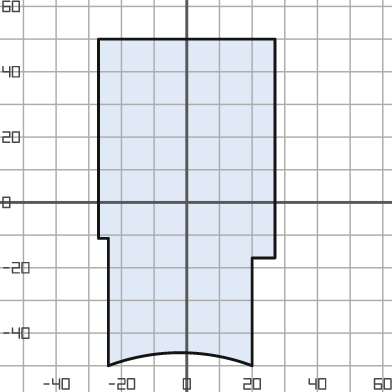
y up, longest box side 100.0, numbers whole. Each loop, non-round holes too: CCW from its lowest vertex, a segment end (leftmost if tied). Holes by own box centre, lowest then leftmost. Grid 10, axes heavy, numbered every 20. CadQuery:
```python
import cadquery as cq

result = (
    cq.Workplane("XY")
    .moveTo(-24.0, -50.0)
    .threePointArc((-2.0, -46.0), (20.0, -50.0))
    .lineTo(20.0, -17.0)
    .lineTo(27.0, -17.0)
    .lineTo(27.0, 50.0)
    .lineTo(-27.0, 50.0)
    .lineTo(-27.0, -11.0)
    .lineTo(-24.0, -11.0)
    .close()
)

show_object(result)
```